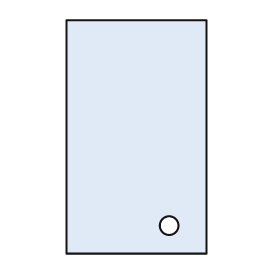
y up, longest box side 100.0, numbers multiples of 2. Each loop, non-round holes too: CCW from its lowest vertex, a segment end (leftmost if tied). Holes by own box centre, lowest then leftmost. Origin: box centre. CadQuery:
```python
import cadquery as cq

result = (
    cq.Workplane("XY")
    .moveTo(-30.0, -50.0)
    .lineTo(30.0, -50.0)
    .lineTo(30.0, 50.0)
    .lineTo(-30.0, 50.0)
    .close()
    .moveTo(14.0, -38.0)
    .circle(4.0)
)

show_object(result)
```